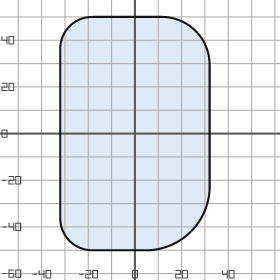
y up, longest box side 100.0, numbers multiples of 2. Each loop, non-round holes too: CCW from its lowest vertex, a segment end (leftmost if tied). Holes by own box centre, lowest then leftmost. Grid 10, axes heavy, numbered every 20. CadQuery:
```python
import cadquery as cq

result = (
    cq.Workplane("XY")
    .moveTo(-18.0, -50.0)
    .lineTo(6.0, -50.0)
    .threePointArc((24.0, -42.0), (32.0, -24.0))
    .lineTo(32.0, 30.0)
    .threePointArc((26.0, 44.0), (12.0, 50.0))
    .lineTo(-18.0, 50.0)
    .threePointArc((-28.0, 46.0), (-32.0, 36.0))
    .lineTo(-32.0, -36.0)
    .threePointArc((-28.0, -46.0), (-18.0, -50.0))
    .close()
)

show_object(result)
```